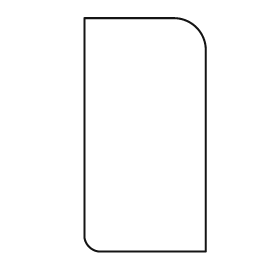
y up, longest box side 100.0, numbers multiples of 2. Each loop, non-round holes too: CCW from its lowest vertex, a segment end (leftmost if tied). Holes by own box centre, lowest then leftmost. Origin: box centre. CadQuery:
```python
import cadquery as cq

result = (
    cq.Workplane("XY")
    .moveTo(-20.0, -50.0)
    .lineTo(26.0, -50.0)
    .lineTo(26.0, 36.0)
    .threePointArc((22.0, 46.0), (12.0, 50.0))
    .lineTo(-26.0, 50.0)
    .lineTo(-26.0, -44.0)
    .threePointArc((-24.0, -48.0), (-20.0, -50.0))
    .close()
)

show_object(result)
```